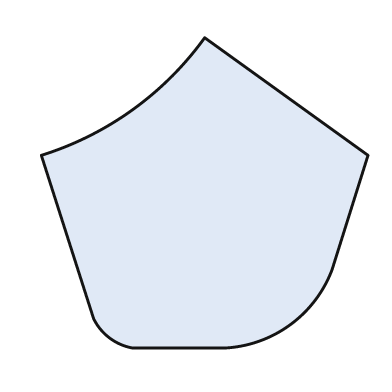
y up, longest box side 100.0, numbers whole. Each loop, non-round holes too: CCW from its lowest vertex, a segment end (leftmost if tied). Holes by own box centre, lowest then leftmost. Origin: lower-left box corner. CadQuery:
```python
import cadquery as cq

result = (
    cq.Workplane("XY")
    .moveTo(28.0, 0.0)
    .lineTo(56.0, 0.0)
    .threePointArc((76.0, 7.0), (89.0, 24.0))
    .lineTo(100.0, 59.0)
    .lineTo(50.0, 95.0)
    .threePointArc((28.0, 73.0), (0.0, 59.0))
    .lineTo(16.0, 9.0)
    .threePointArc((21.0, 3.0), (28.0, 0.0))
    .close()
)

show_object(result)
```